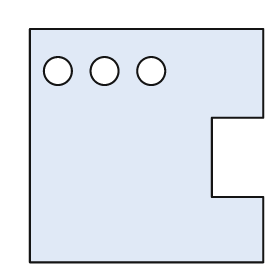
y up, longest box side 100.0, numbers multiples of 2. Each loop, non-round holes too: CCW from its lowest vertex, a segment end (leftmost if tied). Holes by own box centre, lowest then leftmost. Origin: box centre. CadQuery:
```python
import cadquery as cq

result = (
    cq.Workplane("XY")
    .moveTo(-50.0, -50.0)
    .lineTo(50.0, -50.0)
    .lineTo(50.0, -22.0)
    .lineTo(28.0, -22.0)
    .lineTo(28.0, 12.0)
    .lineTo(50.0, 12.0)
    .lineTo(50.0, 50.0)
    .lineTo(-50.0, 50.0)
    .close()
    .moveTo(-38.0, 32.0)
    .circle(6.0)
    .moveTo(-18.0, 32.0)
    .circle(6.0)
    .moveTo(2.0, 32.0)
    .circle(6.0)
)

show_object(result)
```